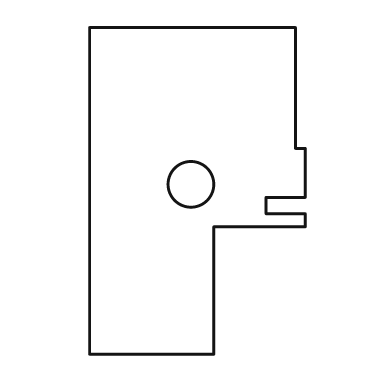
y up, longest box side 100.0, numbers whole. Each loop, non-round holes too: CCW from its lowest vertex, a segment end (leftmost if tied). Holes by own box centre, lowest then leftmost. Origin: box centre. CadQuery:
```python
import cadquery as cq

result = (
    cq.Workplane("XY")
    .moveTo(-33.0, -50.0)
    .lineTo(5.0, -50.0)
    .lineTo(5.0, -11.0)
    .lineTo(33.0, -11.0)
    .lineTo(33.0, -7.0)
    .lineTo(21.0, -7.0)
    .lineTo(21.0, -2.0)
    .lineTo(33.0, -2.0)
    .lineTo(33.0, 13.0)
    .lineTo(30.0, 13.0)
    .lineTo(30.0, 50.0)
    .lineTo(-33.0, 50.0)
    .close()
    .moveTo(-2.0, 2.0)
    .circle(7.0)
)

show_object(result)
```